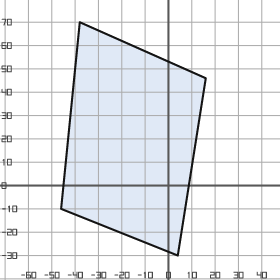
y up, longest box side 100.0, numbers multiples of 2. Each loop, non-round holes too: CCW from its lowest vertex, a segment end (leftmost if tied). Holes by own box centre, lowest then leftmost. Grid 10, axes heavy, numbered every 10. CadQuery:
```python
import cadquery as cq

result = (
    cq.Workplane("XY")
    .moveTo(4.0, -30.0)
    .lineTo(16.0, 46.0)
    .lineTo(-38.0, 70.0)
    .lineTo(-46.0, -10.0)
    .close()
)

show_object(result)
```